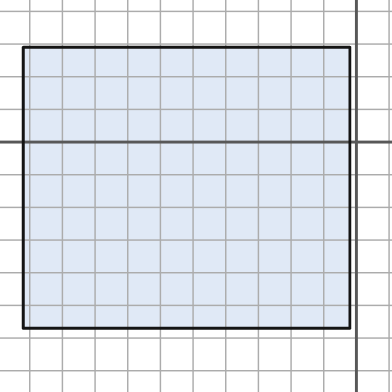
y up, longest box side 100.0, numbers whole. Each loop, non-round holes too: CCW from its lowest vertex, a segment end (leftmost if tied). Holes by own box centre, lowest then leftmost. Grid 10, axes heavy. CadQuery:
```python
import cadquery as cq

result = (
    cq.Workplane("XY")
    .moveTo(-102.0, -57.0)
    .lineTo(-2.0, -57.0)
    .lineTo(-2.0, 29.0)
    .lineTo(-102.0, 29.0)
    .close()
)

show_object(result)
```